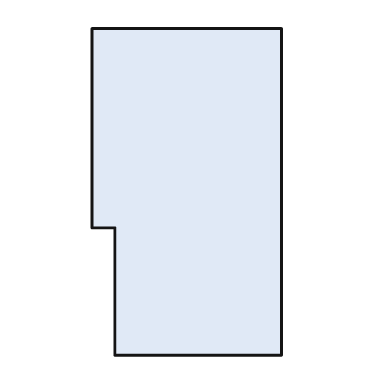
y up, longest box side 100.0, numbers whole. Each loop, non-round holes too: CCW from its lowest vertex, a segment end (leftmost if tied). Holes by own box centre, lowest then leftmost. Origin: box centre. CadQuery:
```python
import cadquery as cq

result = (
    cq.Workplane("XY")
    .moveTo(-22.0, -50.0)
    .lineTo(29.0, -50.0)
    .lineTo(29.0, 50.0)
    .lineTo(-29.0, 50.0)
    .lineTo(-29.0, -11.0)
    .lineTo(-22.0, -11.0)
    .close()
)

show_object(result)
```